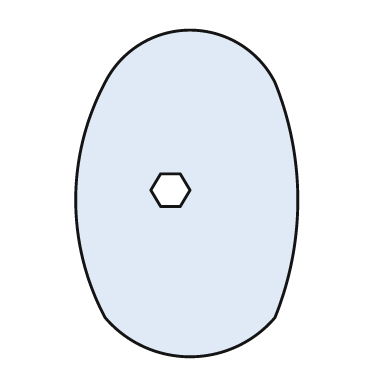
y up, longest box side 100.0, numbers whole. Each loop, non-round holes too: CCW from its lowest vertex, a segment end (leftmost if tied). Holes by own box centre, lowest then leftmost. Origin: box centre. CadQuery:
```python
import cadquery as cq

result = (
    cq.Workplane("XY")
    .moveTo(-25.0, -38.0)
    .threePointArc((1.0, -50.0), (27.0, -38.0))
    .threePointArc((34.0, -2.0), (27.0, 34.0))
    .threePointArc((1.0, 50.0), (-25.0, 34.0))
    .threePointArc((-34.0, -2.0), (-25.0, -38.0))
    .close()
    .moveTo(-8.0, -4.0)
    .lineTo(-2.0, -4.0)
    .lineTo(1.0, 1.0)
    .lineTo(-2.0, 6.0)
    .lineTo(-8.0, 6.0)
    .lineTo(-11.0, 1.0)
    .close()
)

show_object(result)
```